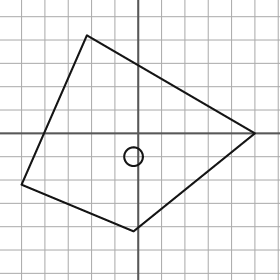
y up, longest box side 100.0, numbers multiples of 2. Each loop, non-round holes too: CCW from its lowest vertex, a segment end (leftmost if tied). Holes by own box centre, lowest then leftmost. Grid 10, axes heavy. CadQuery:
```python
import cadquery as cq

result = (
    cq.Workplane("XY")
    .moveTo(-2.0, -42.0)
    .lineTo(50.0, 0.0)
    .lineTo(-22.0, 42.0)
    .lineTo(-50.0, -22.0)
    .close()
    .moveTo(-2.0, -10.0)
    .circle(4.0)
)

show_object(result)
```